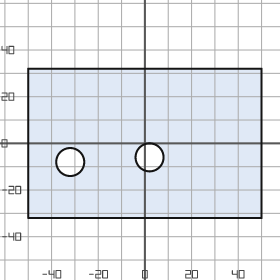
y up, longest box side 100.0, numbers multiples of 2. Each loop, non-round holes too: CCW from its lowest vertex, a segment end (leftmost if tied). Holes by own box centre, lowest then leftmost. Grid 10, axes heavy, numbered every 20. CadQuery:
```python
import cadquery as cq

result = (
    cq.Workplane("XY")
    .moveTo(-50.0, -32.0)
    .lineTo(50.0, -32.0)
    .lineTo(50.0, 32.0)
    .lineTo(-50.0, 32.0)
    .close()
    .moveTo(-32.0, -8.0)
    .circle(6.0)
    .moveTo(2.0, -6.0)
    .circle(6.0)
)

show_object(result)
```